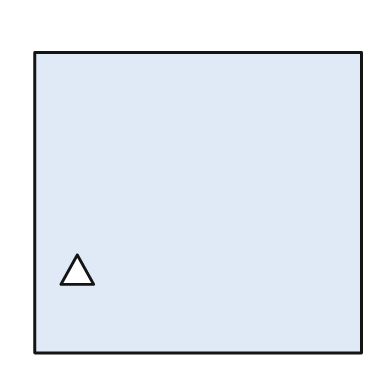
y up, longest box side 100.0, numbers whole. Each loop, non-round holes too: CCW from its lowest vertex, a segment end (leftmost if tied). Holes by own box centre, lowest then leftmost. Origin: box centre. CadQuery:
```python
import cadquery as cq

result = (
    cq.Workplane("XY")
    .moveTo(-50.0, -46.0)
    .lineTo(50.0, -46.0)
    .lineTo(50.0, 46.0)
    .lineTo(-50.0, 46.0)
    .close()
    .moveTo(-42.0, -25.0)
    .lineTo(-32.0, -25.0)
    .lineTo(-37.0, -16.0)
    .close()
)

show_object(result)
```